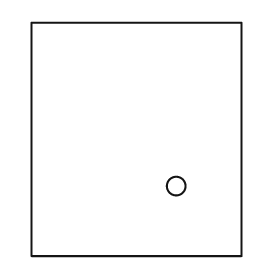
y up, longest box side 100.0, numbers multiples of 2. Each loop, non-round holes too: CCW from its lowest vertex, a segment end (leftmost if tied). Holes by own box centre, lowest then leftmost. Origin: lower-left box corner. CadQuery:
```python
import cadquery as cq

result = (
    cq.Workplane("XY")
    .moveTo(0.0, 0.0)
    .lineTo(90.0, 0.0)
    .lineTo(90.0, 100.0)
    .lineTo(0.0, 100.0)
    .close()
    .moveTo(62.0, 30.0)
    .circle(4.0)
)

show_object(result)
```